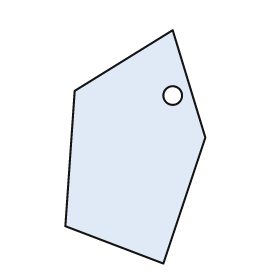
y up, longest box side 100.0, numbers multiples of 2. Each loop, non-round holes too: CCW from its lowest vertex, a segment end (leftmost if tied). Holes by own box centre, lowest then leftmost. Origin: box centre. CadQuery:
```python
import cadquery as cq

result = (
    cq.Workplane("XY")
    .moveTo(12.0, -50.0)
    .lineTo(30.0, 4.0)
    .lineTo(16.0, 50.0)
    .lineTo(-26.0, 24.0)
    .lineTo(-30.0, -34.0)
    .close()
    .moveTo(16.0, 22.0)
    .circle(4.0)
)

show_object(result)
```